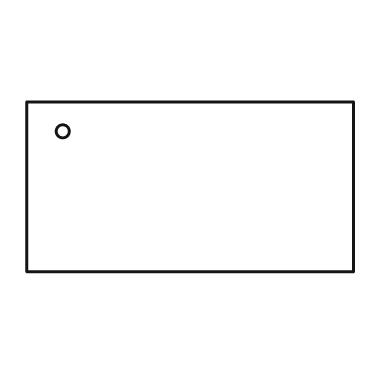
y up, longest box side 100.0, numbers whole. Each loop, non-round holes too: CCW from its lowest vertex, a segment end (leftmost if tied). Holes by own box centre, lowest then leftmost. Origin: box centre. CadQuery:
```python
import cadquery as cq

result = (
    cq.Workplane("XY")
    .moveTo(-50.0, -26.0)
    .lineTo(50.0, -26.0)
    .lineTo(50.0, 26.0)
    .lineTo(-50.0, 26.0)
    .close()
    .moveTo(-39.0, 17.0)
    .circle(2.0)
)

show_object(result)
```